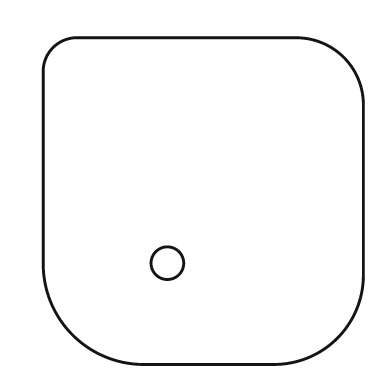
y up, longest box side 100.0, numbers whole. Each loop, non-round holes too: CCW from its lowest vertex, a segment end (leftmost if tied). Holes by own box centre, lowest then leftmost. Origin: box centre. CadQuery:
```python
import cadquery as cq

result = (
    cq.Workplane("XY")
    .moveTo(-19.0, -50.0)
    .lineTo(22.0, -50.0)
    .threePointArc((41.0, -42.0), (49.0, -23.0))
    .lineTo(49.0, 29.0)
    .threePointArc((43.0, 44.0), (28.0, 50.0))
    .lineTo(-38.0, 50.0)
    .threePointArc((-46.0, 47.0), (-49.0, 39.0))
    .lineTo(-49.0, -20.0)
    .threePointArc((-40.0, -41.0), (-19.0, -50.0))
    .close()
    .moveTo(-11.0, -19.0)
    .circle(5.0)
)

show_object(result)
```